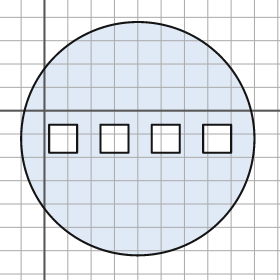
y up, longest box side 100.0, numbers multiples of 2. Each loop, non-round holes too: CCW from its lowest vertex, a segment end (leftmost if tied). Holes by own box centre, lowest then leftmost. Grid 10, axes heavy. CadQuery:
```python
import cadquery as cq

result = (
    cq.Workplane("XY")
    .moveTo(40.0, -12.0)
    .circle(50.0)
    .moveTo(2.0, -18.0)
    .lineTo(14.0, -18.0)
    .lineTo(14.0, -6.0)
    .lineTo(2.0, -6.0)
    .close()
    .moveTo(24.0, -18.0)
    .lineTo(36.0, -18.0)
    .lineTo(36.0, -6.0)
    .lineTo(24.0, -6.0)
    .close()
    .moveTo(46.0, -18.0)
    .lineTo(58.0, -18.0)
    .lineTo(58.0, -6.0)
    .lineTo(46.0, -6.0)
    .close()
    .moveTo(68.0, -18.0)
    .lineTo(80.0, -18.0)
    .lineTo(80.0, -6.0)
    .lineTo(68.0, -6.0)
    .close()
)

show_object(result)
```